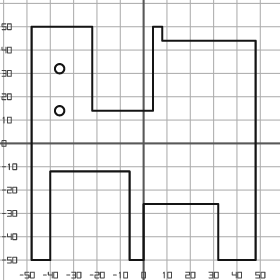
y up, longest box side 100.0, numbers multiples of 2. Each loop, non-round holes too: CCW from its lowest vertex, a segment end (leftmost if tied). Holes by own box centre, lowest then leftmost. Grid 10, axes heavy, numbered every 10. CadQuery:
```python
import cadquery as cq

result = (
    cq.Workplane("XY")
    .moveTo(-48.0, -50.0)
    .lineTo(-40.0, -50.0)
    .lineTo(-40.0, -12.0)
    .lineTo(-6.0, -12.0)
    .lineTo(-6.0, -50.0)
    .lineTo(0.0, -50.0)
    .lineTo(0.0, -26.0)
    .lineTo(32.0, -26.0)
    .lineTo(32.0, -50.0)
    .lineTo(48.0, -50.0)
    .lineTo(48.0, 44.0)
    .lineTo(8.0, 44.0)
    .lineTo(8.0, 50.0)
    .lineTo(4.0, 50.0)
    .lineTo(4.0, 14.0)
    .lineTo(-22.0, 14.0)
    .lineTo(-22.0, 50.0)
    .lineTo(-48.0, 50.0)
    .close()
    .moveTo(-36.0, 14.0)
    .circle(2.0)
    .moveTo(-36.0, 32.0)
    .circle(2.0)
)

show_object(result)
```